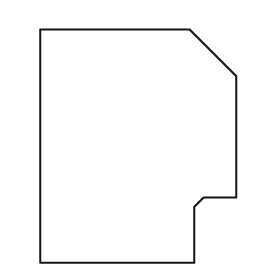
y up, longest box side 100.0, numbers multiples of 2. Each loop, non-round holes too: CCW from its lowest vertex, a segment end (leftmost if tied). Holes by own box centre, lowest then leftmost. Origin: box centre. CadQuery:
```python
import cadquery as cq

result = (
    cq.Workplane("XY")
    .moveTo(-42.0, -50.0)
    .lineTo(24.0, -50.0)
    .lineTo(24.0, -26.0)
    .lineTo(28.0, -22.0)
    .lineTo(42.0, -22.0)
    .lineTo(42.0, 30.0)
    .lineTo(22.0, 50.0)
    .lineTo(-42.0, 50.0)
    .close()
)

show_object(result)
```